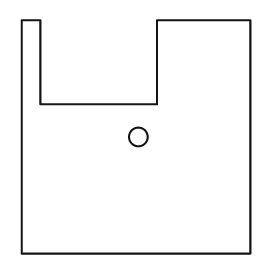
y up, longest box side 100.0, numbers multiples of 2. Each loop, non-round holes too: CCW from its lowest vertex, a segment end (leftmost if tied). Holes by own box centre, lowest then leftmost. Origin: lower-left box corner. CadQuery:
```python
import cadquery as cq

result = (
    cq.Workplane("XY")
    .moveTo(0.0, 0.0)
    .lineTo(98.0, 0.0)
    .lineTo(98.0, 100.0)
    .lineTo(58.0, 100.0)
    .lineTo(58.0, 64.0)
    .lineTo(8.0, 64.0)
    .lineTo(8.0, 100.0)
    .lineTo(0.0, 100.0)
    .close()
    .moveTo(50.0, 50.0)
    .circle(4.0)
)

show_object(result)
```